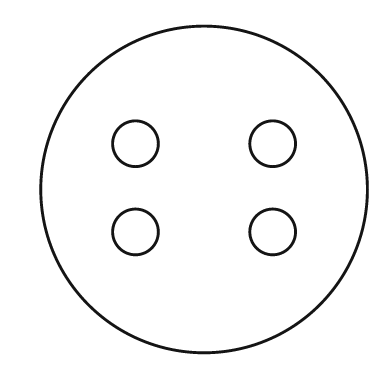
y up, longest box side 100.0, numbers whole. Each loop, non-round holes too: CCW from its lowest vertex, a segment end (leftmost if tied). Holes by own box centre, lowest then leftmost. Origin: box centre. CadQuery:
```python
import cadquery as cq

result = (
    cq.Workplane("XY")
    .moveTo(0.0, 0.0)
    .circle(50.0)
    .moveTo(-21.0, -13.0)
    .circle(7.0)
    .moveTo(21.0, -13.0)
    .circle(7.0)
    .moveTo(-21.0, 14.0)
    .circle(7.0)
    .moveTo(21.0, 14.0)
    .circle(7.0)
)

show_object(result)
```